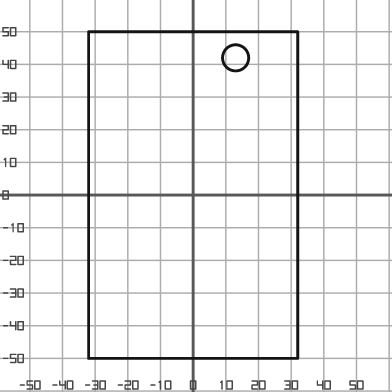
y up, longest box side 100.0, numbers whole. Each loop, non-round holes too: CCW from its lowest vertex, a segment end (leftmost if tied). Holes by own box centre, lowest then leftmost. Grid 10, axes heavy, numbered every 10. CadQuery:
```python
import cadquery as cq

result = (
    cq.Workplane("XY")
    .moveTo(-32.0, -50.0)
    .lineTo(32.0, -50.0)
    .lineTo(32.0, 50.0)
    .lineTo(-32.0, 50.0)
    .close()
    .moveTo(13.0, 42.0)
    .circle(4.0)
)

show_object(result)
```